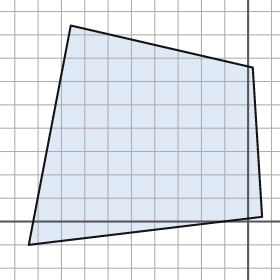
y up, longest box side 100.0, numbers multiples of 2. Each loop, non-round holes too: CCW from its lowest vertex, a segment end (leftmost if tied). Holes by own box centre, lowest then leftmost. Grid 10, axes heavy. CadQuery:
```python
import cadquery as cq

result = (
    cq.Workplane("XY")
    .moveTo(-94.0, -10.0)
    .lineTo(6.0, 2.0)
    .lineTo(2.0, 66.0)
    .lineTo(-76.0, 84.0)
    .close()
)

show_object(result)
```